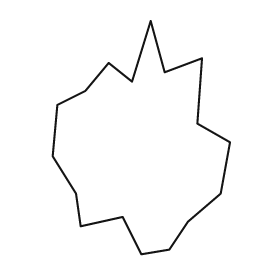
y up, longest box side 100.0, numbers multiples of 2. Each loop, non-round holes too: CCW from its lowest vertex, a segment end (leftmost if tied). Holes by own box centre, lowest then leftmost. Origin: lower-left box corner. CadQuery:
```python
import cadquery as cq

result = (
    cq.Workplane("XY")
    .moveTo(38.0, 0.0)
    .lineTo(50.0, 2.0)
    .lineTo(58.0, 14.0)
    .lineTo(72.0, 26.0)
    .lineTo(76.0, 48.0)
    .lineTo(62.0, 56.0)
    .lineTo(64.0, 84.0)
    .lineTo(48.0, 78.0)
    .lineTo(42.0, 100.0)
    .lineTo(34.0, 74.0)
    .lineTo(24.0, 82.0)
    .lineTo(14.0, 70.0)
    .lineTo(2.0, 64.0)
    .lineTo(0.0, 42.0)
    .lineTo(10.0, 26.0)
    .lineTo(12.0, 12.0)
    .lineTo(30.0, 16.0)
    .close()
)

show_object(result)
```